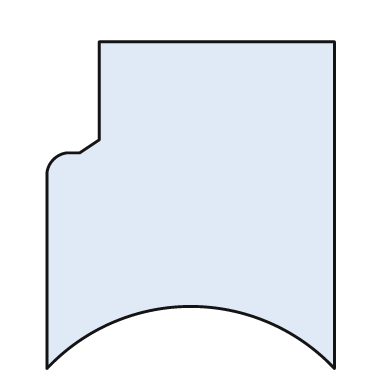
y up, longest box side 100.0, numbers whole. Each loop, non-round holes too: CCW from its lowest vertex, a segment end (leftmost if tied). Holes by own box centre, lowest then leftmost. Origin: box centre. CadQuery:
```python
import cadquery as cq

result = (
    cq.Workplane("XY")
    .moveTo(-44.0, -50.0)
    .threePointArc((0.0, -31.0), (44.0, -50.0))
    .lineTo(44.0, 50.0)
    .lineTo(-28.0, 50.0)
    .lineTo(-28.0, 20.0)
    .lineTo(-34.0, 16.0)
    .lineTo(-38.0, 16.0)
    .threePointArc((-42.0, 14.0), (-44.0, 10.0))
    .close()
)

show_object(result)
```